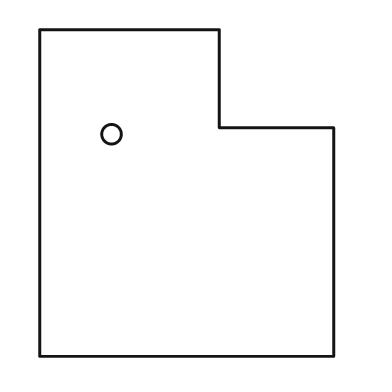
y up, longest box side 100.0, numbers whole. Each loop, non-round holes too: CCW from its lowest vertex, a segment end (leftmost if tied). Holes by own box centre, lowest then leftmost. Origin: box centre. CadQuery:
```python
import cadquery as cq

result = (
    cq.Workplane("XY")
    .moveTo(-45.0, -50.0)
    .lineTo(45.0, -50.0)
    .lineTo(45.0, 20.0)
    .lineTo(10.0, 20.0)
    .lineTo(10.0, 50.0)
    .lineTo(-45.0, 50.0)
    .close()
    .moveTo(-23.0, 18.0)
    .circle(3.0)
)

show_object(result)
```